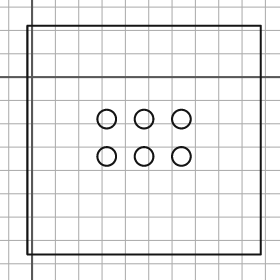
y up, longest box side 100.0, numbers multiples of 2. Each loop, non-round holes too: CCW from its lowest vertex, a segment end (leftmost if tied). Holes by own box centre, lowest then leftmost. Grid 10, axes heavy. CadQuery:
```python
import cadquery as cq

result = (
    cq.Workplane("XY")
    .moveTo(-2.0, -76.0)
    .lineTo(98.0, -76.0)
    .lineTo(98.0, 22.0)
    .lineTo(-2.0, 22.0)
    .close()
    .moveTo(32.0, -34.0)
    .circle(4.0)
    .moveTo(48.0, -34.0)
    .circle(4.0)
    .moveTo(64.0, -34.0)
    .circle(4.0)
    .moveTo(32.0, -18.0)
    .circle(4.0)
    .moveTo(48.0, -18.0)
    .circle(4.0)
    .moveTo(64.0, -18.0)
    .circle(4.0)
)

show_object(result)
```